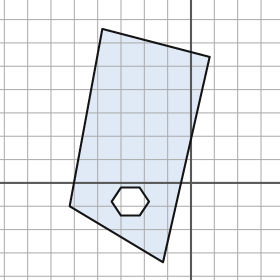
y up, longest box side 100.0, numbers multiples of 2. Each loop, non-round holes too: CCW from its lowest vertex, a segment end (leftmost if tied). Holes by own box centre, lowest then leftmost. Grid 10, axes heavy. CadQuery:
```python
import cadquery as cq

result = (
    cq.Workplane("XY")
    .moveTo(-12.0, -34.0)
    .lineTo(8.0, 54.0)
    .lineTo(-38.0, 66.0)
    .lineTo(-52.0, -10.0)
    .close()
    .moveTo(-30.0, -14.0)
    .lineTo(-22.0, -14.0)
    .lineTo(-18.0, -8.0)
    .lineTo(-22.0, -2.0)
    .lineTo(-30.0, -2.0)
    .lineTo(-34.0, -8.0)
    .close()
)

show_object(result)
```